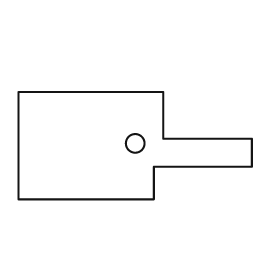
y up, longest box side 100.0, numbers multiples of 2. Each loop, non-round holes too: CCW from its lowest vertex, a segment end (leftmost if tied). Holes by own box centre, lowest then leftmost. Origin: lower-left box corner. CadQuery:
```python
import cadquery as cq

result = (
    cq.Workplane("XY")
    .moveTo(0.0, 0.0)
    .lineTo(58.0, 0.0)
    .lineTo(58.0, 14.0)
    .lineTo(100.0, 14.0)
    .lineTo(100.0, 26.0)
    .lineTo(62.0, 26.0)
    .lineTo(62.0, 46.0)
    .lineTo(0.0, 46.0)
    .close()
    .moveTo(50.0, 24.0)
    .circle(4.0)
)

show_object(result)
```